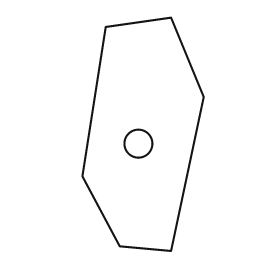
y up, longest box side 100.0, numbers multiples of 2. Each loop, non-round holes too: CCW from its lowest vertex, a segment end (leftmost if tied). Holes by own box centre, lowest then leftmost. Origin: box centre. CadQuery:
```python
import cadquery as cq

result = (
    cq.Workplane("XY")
    .moveTo(12.0, -50.0)
    .lineTo(26.0, 16.0)
    .lineTo(12.0, 50.0)
    .lineTo(-16.0, 46.0)
    .lineTo(-26.0, -18.0)
    .lineTo(-10.0, -48.0)
    .close()
    .moveTo(-2.0, -4.0)
    .circle(6.0)
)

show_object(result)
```